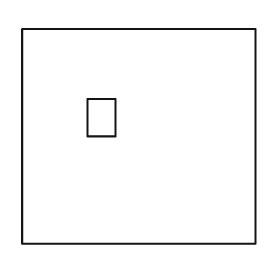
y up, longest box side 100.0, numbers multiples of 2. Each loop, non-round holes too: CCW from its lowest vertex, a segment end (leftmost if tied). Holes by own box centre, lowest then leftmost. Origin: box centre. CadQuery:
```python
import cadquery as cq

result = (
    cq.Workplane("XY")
    .moveTo(-50.0, -46.0)
    .lineTo(50.0, -46.0)
    .lineTo(50.0, 46.0)
    .lineTo(-50.0, 46.0)
    .close()
    .moveTo(-22.0, 0.0)
    .lineTo(-10.0, 0.0)
    .lineTo(-10.0, 16.0)
    .lineTo(-22.0, 16.0)
    .close()
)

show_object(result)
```